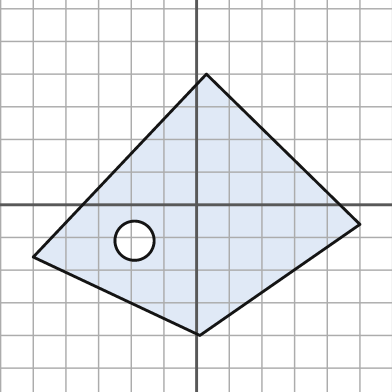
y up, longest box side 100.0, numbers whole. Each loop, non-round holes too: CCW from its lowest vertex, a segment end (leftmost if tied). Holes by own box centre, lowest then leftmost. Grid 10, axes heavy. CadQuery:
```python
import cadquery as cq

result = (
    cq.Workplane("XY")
    .moveTo(1.0, -40.0)
    .lineTo(50.0, -6.0)
    .lineTo(3.0, 40.0)
    .lineTo(-50.0, -16.0)
    .close()
    .moveTo(-19.0, -11.0)
    .circle(6.0)
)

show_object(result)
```